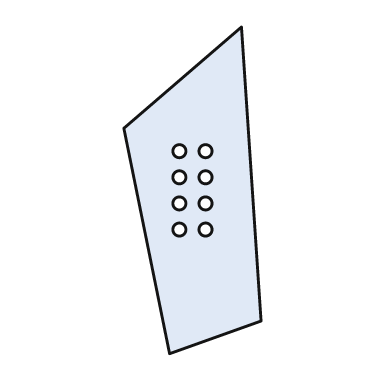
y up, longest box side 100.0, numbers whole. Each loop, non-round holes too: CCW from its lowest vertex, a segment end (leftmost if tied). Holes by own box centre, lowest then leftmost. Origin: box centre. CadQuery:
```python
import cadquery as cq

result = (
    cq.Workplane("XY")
    .moveTo(-7.0, -50.0)
    .lineTo(21.0, -40.0)
    .lineTo(15.0, 50.0)
    .lineTo(-21.0, 19.0)
    .close()
    .moveTo(-4.0, -12.0)
    .circle(2.0)
    .moveTo(4.0, -12.0)
    .circle(2.0)
    .moveTo(-4.0, -4.0)
    .circle(2.0)
    .moveTo(4.0, -4.0)
    .circle(2.0)
    .moveTo(-4.0, 4.0)
    .circle(2.0)
    .moveTo(4.0, 4.0)
    .circle(2.0)
    .moveTo(-4.0, 12.0)
    .circle(2.0)
    .moveTo(4.0, 12.0)
    .circle(2.0)
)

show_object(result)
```